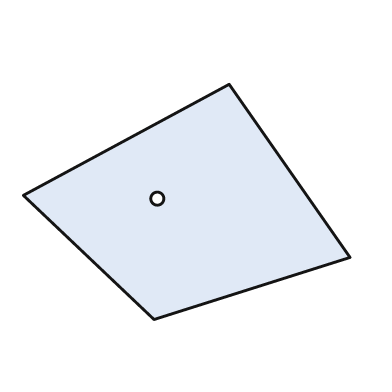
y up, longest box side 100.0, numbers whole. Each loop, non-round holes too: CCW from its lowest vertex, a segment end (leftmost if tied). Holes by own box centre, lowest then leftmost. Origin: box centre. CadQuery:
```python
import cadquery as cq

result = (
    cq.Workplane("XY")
    .moveTo(-10.0, -36.0)
    .lineTo(50.0, -17.0)
    .lineTo(13.0, 36.0)
    .lineTo(-50.0, 2.0)
    .close()
    .moveTo(-9.0, 1.0)
    .circle(2.0)
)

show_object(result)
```